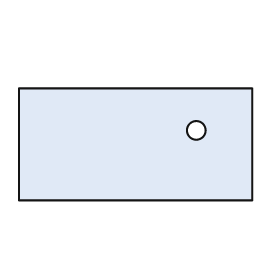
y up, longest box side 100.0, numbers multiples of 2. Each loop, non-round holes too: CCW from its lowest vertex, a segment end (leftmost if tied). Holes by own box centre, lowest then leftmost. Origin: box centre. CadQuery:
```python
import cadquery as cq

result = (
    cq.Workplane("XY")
    .moveTo(-50.0, -24.0)
    .lineTo(50.0, -24.0)
    .lineTo(50.0, 24.0)
    .lineTo(-50.0, 24.0)
    .close()
    .moveTo(26.0, 6.0)
    .circle(4.0)
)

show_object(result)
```